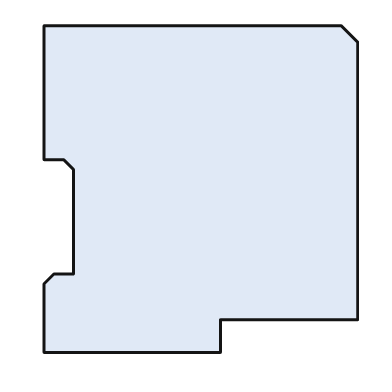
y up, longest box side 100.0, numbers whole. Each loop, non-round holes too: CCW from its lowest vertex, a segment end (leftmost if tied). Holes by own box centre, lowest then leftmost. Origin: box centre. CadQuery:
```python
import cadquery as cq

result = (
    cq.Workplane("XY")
    .moveTo(-48.0, -50.0)
    .lineTo(6.0, -50.0)
    .lineTo(6.0, -40.0)
    .lineTo(48.0, -40.0)
    .lineTo(48.0, 45.0)
    .lineTo(43.0, 50.0)
    .lineTo(-48.0, 50.0)
    .lineTo(-48.0, 9.0)
    .lineTo(-42.0, 9.0)
    .lineTo(-39.0, 6.0)
    .lineTo(-39.0, -26.0)
    .lineTo(-45.0, -26.0)
    .lineTo(-48.0, -29.0)
    .close()
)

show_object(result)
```